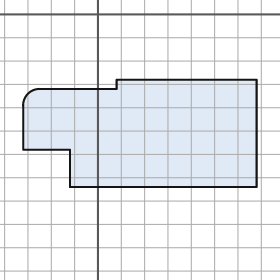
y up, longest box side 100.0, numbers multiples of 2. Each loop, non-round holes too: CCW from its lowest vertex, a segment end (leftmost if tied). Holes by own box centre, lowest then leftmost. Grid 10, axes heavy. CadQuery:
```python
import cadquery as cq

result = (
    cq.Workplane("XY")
    .moveTo(-12.0, -74.0)
    .lineTo(68.0, -74.0)
    .lineTo(68.0, -28.0)
    .lineTo(8.0, -28.0)
    .lineTo(8.0, -32.0)
    .lineTo(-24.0, -32.0)
    .threePointArc((-30.0, -34.0), (-32.0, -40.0))
    .lineTo(-32.0, -58.0)
    .lineTo(-12.0, -58.0)
    .close()
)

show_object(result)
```